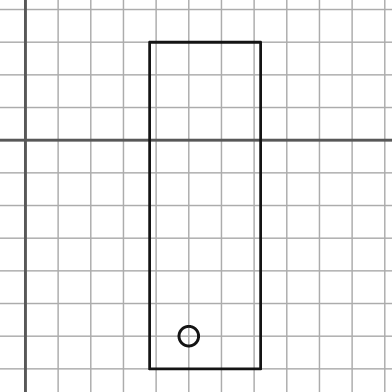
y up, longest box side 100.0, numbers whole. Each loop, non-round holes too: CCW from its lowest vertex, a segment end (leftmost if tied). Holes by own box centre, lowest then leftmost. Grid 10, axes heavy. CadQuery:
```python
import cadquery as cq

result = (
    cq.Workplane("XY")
    .moveTo(38.0, -70.0)
    .lineTo(72.0, -70.0)
    .lineTo(72.0, 30.0)
    .lineTo(38.0, 30.0)
    .close()
    .moveTo(50.0, -60.0)
    .circle(3.0)
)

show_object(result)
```